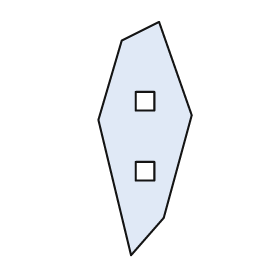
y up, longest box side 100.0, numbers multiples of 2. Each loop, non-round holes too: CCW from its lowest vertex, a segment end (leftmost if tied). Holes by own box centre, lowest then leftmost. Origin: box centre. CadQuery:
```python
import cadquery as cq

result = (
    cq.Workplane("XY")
    .moveTo(-6.0, -50.0)
    .lineTo(8.0, -34.0)
    .lineTo(20.0, 10.0)
    .lineTo(6.0, 50.0)
    .lineTo(-10.0, 42.0)
    .lineTo(-20.0, 8.0)
    .close()
    .moveTo(-4.0, -18.0)
    .lineTo(4.0, -18.0)
    .lineTo(4.0, -10.0)
    .lineTo(-4.0, -10.0)
    .close()
    .moveTo(-4.0, 12.0)
    .lineTo(4.0, 12.0)
    .lineTo(4.0, 20.0)
    .lineTo(-4.0, 20.0)
    .close()
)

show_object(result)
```